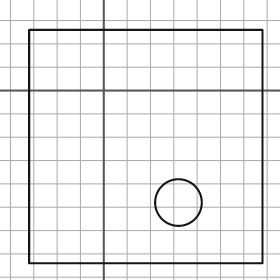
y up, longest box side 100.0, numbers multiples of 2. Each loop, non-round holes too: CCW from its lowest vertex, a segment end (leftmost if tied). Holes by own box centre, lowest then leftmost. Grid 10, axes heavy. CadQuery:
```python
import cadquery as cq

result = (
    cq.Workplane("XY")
    .moveTo(-32.0, -74.0)
    .lineTo(68.0, -74.0)
    .lineTo(68.0, 26.0)
    .lineTo(-32.0, 26.0)
    .close()
    .moveTo(32.0, -48.0)
    .circle(10.0)
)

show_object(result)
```